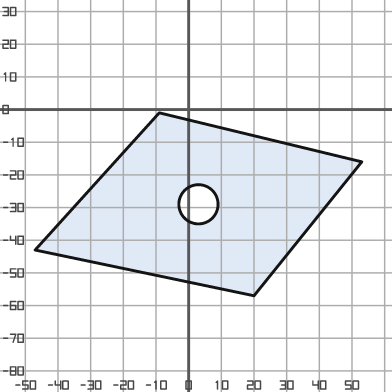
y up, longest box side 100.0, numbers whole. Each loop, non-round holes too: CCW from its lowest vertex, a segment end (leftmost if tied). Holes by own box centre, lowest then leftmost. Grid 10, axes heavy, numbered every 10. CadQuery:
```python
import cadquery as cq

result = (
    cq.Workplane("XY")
    .moveTo(20.0, -57.0)
    .lineTo(53.0, -16.0)
    .lineTo(-9.0, -1.0)
    .lineTo(-47.0, -43.0)
    .close()
    .moveTo(3.0, -29.0)
    .circle(6.0)
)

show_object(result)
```